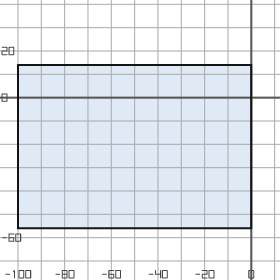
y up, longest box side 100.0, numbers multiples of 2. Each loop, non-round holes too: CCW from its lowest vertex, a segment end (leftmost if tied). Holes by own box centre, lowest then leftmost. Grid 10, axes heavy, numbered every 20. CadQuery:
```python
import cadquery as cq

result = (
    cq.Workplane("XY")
    .moveTo(-100.0, -56.0)
    .lineTo(0.0, -56.0)
    .lineTo(0.0, 14.0)
    .lineTo(-100.0, 14.0)
    .close()
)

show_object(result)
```